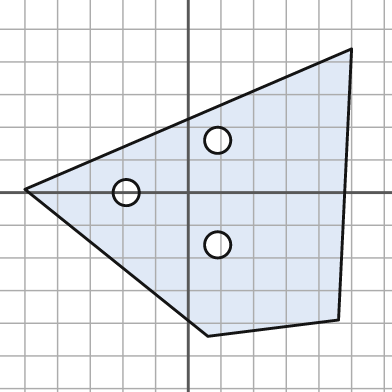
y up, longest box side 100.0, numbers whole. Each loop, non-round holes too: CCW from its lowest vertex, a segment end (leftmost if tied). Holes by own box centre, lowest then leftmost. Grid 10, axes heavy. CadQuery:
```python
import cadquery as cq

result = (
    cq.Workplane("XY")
    .moveTo(6.0, -44.0)
    .lineTo(46.0, -39.0)
    .lineTo(50.0, 44.0)
    .lineTo(-50.0, 1.0)
    .close()
    .moveTo(9.0, -16.0)
    .circle(4.0)
    .moveTo(-19.0, 0.0)
    .circle(4.0)
    .moveTo(9.0, 16.0)
    .circle(4.0)
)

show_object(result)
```